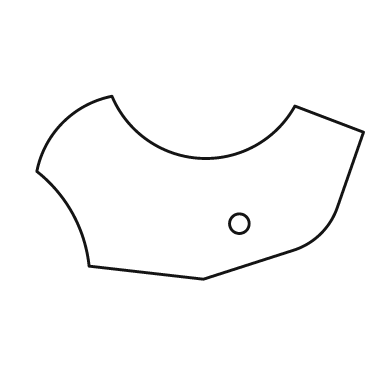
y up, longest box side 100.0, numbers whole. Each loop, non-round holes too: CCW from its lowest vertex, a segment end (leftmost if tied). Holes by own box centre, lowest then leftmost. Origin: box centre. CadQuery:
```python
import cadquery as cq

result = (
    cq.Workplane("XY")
    .moveTo(1.0, -28.0)
    .lineTo(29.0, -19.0)
    .threePointArc((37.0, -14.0), (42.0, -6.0))
    .lineTo(50.0, 17.0)
    .lineTo(29.0, 25.0)
    .threePointArc((0.0, 9.0), (-27.0, 28.0))
    .threePointArc((-42.0, 20.0), (-50.0, 5.0))
    .threePointArc((-39.0, -8.0), (-34.0, -24.0))
    .close()
    .moveTo(12.0, -11.0)
    .circle(3.0)
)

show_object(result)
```